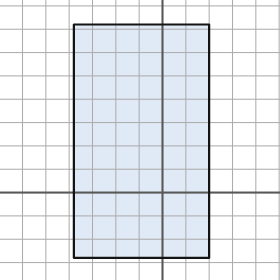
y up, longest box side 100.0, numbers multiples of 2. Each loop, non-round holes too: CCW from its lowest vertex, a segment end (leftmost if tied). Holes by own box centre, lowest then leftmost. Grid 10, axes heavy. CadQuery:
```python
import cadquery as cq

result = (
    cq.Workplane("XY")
    .moveTo(-38.0, -28.0)
    .lineTo(20.0, -28.0)
    .lineTo(20.0, 72.0)
    .lineTo(-38.0, 72.0)
    .close()
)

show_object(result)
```